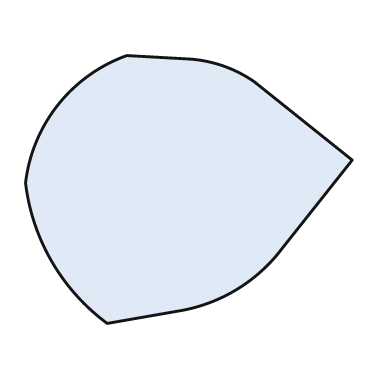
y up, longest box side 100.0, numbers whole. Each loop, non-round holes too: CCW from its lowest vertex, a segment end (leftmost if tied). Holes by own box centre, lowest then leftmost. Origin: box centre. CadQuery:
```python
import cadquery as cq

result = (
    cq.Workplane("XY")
    .moveTo(-25.0, -41.0)
    .lineTo(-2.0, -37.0)
    .threePointArc((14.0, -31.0), (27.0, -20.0))
    .lineTo(50.0, 9.0)
    .lineTo(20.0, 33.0)
    .threePointArc((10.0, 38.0), (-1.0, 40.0))
    .lineTo(-19.0, 41.0)
    .threePointArc((-40.0, 26.0), (-50.0, 2.0))
    .threePointArc((-42.0, -22.0), (-25.0, -41.0))
    .close()
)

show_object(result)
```